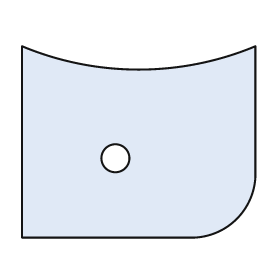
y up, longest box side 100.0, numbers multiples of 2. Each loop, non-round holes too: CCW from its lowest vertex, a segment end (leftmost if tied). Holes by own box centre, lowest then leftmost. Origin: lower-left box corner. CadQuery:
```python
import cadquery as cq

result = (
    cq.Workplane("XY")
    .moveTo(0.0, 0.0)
    .lineTo(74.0, 0.0)
    .threePointArc((92.0, 8.0), (100.0, 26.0))
    .lineTo(100.0, 82.0)
    .threePointArc((50.0, 72.0), (0.0, 82.0))
    .close()
    .moveTo(40.0, 34.0)
    .circle(6.0)
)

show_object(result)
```